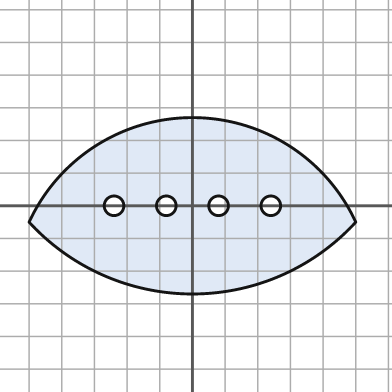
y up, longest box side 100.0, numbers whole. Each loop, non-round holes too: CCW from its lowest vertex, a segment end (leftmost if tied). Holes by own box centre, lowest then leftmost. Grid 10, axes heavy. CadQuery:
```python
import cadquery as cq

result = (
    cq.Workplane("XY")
    .moveTo(-50.0, -5.0)
    .threePointArc((0.0, -27.0), (50.0, -5.0))
    .threePointArc((0.0, 27.0), (-50.0, -5.0))
    .close()
    .moveTo(-24.0, 0.0)
    .circle(3.0)
    .moveTo(-8.0, 0.0)
    .circle(3.0)
    .moveTo(8.0, 0.0)
    .circle(3.0)
    .moveTo(24.0, 0.0)
    .circle(3.0)
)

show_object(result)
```